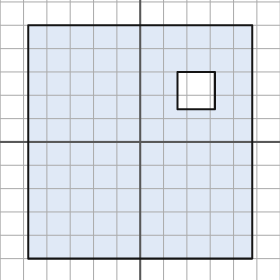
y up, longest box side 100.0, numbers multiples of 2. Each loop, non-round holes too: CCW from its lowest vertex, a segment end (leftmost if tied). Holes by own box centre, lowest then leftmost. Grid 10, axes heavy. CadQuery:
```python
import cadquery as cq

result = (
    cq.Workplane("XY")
    .moveTo(-48.0, -50.0)
    .lineTo(48.0, -50.0)
    .lineTo(48.0, 50.0)
    .lineTo(-48.0, 50.0)
    .close()
    .moveTo(16.0, 14.0)
    .lineTo(32.0, 14.0)
    .lineTo(32.0, 30.0)
    .lineTo(16.0, 30.0)
    .close()
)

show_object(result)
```